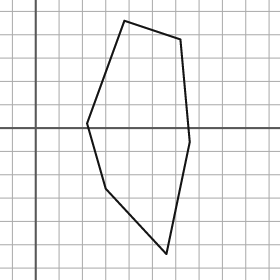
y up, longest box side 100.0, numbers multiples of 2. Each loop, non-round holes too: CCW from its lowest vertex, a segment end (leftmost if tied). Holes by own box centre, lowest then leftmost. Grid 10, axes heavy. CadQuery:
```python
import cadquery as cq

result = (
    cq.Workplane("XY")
    .moveTo(56.0, -54.0)
    .lineTo(66.0, -6.0)
    .lineTo(62.0, 38.0)
    .lineTo(38.0, 46.0)
    .lineTo(22.0, 2.0)
    .lineTo(30.0, -26.0)
    .close()
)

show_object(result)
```